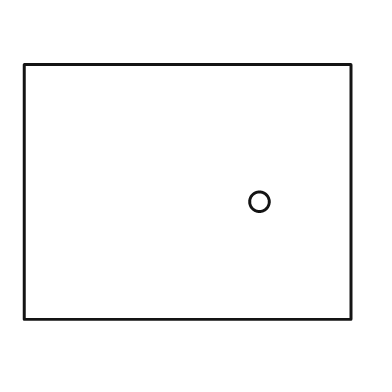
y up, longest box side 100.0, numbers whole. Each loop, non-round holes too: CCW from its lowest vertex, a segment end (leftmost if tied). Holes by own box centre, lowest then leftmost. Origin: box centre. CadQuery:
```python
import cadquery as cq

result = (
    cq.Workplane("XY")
    .moveTo(-50.0, -39.0)
    .lineTo(50.0, -39.0)
    .lineTo(50.0, 39.0)
    .lineTo(-50.0, 39.0)
    .close()
    .moveTo(22.0, -3.0)
    .circle(3.0)
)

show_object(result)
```